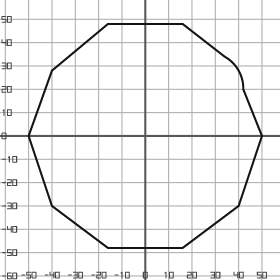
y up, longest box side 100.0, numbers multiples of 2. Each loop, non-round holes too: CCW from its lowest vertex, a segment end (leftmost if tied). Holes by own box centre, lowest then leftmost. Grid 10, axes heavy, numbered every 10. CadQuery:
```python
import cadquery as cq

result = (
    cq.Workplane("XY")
    .moveTo(-16.0, -48.0)
    .lineTo(16.0, -48.0)
    .lineTo(40.0, -30.0)
    .lineTo(50.0, 0.0)
    .lineTo(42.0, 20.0)
    .threePointArc((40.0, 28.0), (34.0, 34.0))
    .lineTo(16.0, 48.0)
    .lineTo(-16.0, 48.0)
    .lineTo(-40.0, 28.0)
    .lineTo(-50.0, 0.0)
    .lineTo(-40.0, -30.0)
    .close()
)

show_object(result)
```